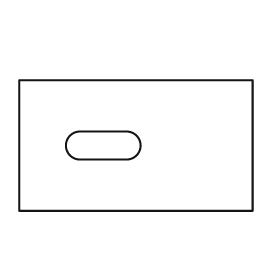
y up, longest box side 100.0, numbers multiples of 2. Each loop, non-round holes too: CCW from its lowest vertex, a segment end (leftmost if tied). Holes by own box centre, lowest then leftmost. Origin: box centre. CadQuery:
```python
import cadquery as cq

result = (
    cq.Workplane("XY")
    .moveTo(-50.0, -28.0)
    .lineTo(50.0, -28.0)
    .lineTo(50.0, 28.0)
    .lineTo(-50.0, 28.0)
    .close()
    .moveTo(-24.0, -6.0)
    .lineTo(-4.0, -6.0)
    .threePointArc((2.0, 0.0), (-4.0, 6.0))
    .lineTo(-24.0, 6.0)
    .threePointArc((-30.0, 0.0), (-24.0, -6.0))
    .close()
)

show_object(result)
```